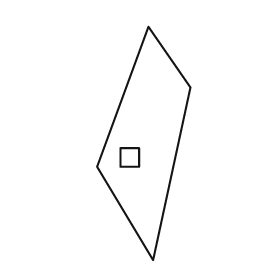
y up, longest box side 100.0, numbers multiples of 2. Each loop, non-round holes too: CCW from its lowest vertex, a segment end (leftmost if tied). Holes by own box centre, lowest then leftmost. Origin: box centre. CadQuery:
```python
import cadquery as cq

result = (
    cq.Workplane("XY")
    .moveTo(4.0, -50.0)
    .lineTo(20.0, 24.0)
    .lineTo(2.0, 50.0)
    .lineTo(-20.0, -10.0)
    .close()
    .moveTo(-10.0, -10.0)
    .lineTo(-2.0, -10.0)
    .lineTo(-2.0, -2.0)
    .lineTo(-10.0, -2.0)
    .close()
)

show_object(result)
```